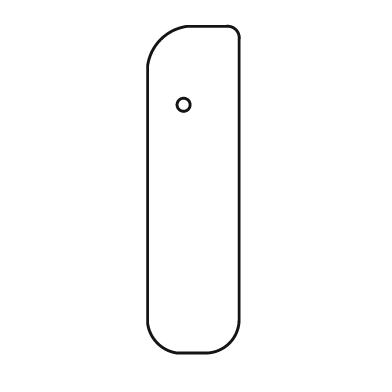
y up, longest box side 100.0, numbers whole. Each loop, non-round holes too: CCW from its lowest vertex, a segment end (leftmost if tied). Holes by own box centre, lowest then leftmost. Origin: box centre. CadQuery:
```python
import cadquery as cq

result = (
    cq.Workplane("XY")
    .moveTo(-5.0, -50.0)
    .lineTo(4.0, -50.0)
    .threePointArc((11.0, -47.0), (14.0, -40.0))
    .lineTo(14.0, 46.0)
    .threePointArc((13.0, 49.0), (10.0, 50.0))
    .lineTo(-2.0, 50.0)
    .threePointArc((-10.0, 46.0), (-14.0, 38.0))
    .lineTo(-14.0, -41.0)
    .threePointArc((-11.0, -47.0), (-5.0, -50.0))
    .close()
    .moveTo(-3.0, 26.0)
    .circle(2.0)
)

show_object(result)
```